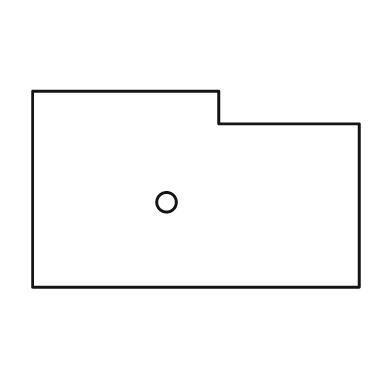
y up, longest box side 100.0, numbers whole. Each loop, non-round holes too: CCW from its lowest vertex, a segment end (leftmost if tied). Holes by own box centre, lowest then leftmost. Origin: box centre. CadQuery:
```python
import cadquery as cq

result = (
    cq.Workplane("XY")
    .moveTo(-50.0, -30.0)
    .lineTo(50.0, -30.0)
    .lineTo(50.0, 20.0)
    .lineTo(7.0, 20.0)
    .lineTo(7.0, 30.0)
    .lineTo(-50.0, 30.0)
    .close()
    .moveTo(-9.0, -4.0)
    .circle(3.0)
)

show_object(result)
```